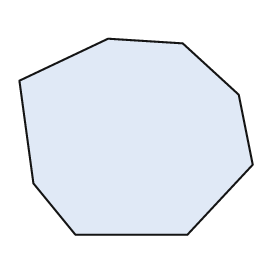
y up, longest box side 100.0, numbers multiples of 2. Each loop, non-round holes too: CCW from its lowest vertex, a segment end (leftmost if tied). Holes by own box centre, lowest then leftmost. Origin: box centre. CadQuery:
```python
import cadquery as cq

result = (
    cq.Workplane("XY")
    .moveTo(-26.0, -42.0)
    .lineTo(22.0, -42.0)
    .lineTo(50.0, -12.0)
    .lineTo(44.0, 18.0)
    .lineTo(20.0, 40.0)
    .lineTo(-12.0, 42.0)
    .lineTo(-50.0, 24.0)
    .lineTo(-44.0, -20.0)
    .close()
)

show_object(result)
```